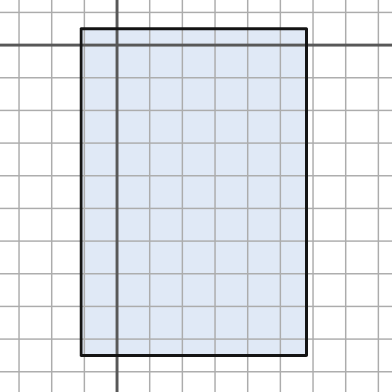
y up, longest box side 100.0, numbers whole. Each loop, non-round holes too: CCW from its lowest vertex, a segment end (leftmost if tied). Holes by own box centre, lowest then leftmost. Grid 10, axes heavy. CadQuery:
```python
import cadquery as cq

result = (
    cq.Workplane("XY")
    .moveTo(-11.0, -95.0)
    .lineTo(58.0, -95.0)
    .lineTo(58.0, 5.0)
    .lineTo(-11.0, 5.0)
    .close()
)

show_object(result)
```